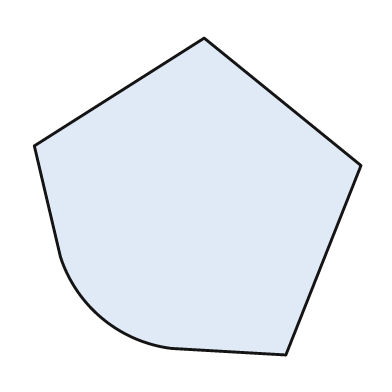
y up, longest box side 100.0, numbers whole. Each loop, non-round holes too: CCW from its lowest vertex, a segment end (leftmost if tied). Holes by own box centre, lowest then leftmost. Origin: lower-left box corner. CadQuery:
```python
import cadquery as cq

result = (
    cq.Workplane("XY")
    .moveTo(77.0, 0.0)
    .lineTo(100.0, 58.0)
    .lineTo(52.0, 97.0)
    .lineTo(0.0, 64.0)
    .lineTo(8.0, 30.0)
    .threePointArc((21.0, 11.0), (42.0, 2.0))
    .close()
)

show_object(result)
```